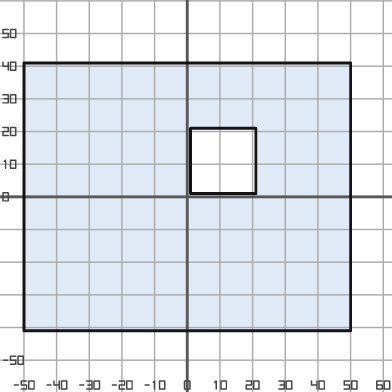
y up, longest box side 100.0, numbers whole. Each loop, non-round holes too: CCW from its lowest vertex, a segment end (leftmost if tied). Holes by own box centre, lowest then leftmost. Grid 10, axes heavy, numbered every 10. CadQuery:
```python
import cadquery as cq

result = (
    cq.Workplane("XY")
    .moveTo(-50.0, -41.0)
    .lineTo(50.0, -41.0)
    .lineTo(50.0, 41.0)
    .lineTo(-50.0, 41.0)
    .close()
    .moveTo(1.0, 1.0)
    .lineTo(21.0, 1.0)
    .lineTo(21.0, 21.0)
    .lineTo(1.0, 21.0)
    .close()
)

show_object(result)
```